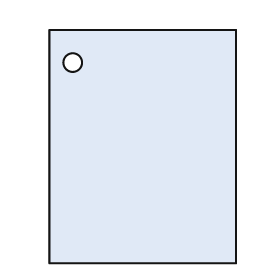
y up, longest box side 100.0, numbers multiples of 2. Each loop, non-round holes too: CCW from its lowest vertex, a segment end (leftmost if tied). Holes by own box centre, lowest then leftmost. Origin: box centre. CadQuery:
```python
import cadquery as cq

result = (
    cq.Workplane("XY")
    .moveTo(-40.0, -50.0)
    .lineTo(40.0, -50.0)
    .lineTo(40.0, 50.0)
    .lineTo(-40.0, 50.0)
    .close()
    .moveTo(-30.0, 36.0)
    .circle(4.0)
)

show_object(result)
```